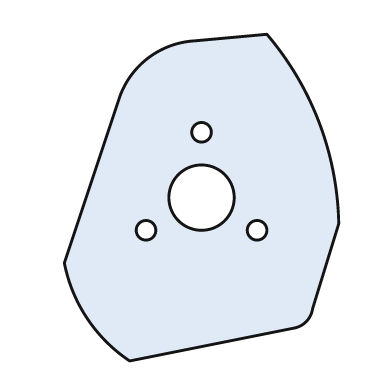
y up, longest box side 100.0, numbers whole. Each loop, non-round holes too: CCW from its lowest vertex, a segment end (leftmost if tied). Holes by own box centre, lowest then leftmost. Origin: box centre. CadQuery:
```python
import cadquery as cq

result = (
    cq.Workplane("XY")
    .moveTo(-22.0, -50.0)
    .lineTo(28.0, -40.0)
    .threePointArc((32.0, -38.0), (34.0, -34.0))
    .lineTo(42.0, -8.0)
    .threePointArc((36.0, 23.0), (20.0, 50.0))
    .lineTo(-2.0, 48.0)
    .threePointArc((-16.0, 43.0), (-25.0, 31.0))
    .lineTo(-42.0, -20.0)
    .threePointArc((-35.0, -37.0), (-22.0, -50.0))
    .close()
    .moveTo(-17.0, -10.0)
    .circle(3.0)
    .moveTo(17.0, -10.0)
    .circle(3.0)
    .moveTo(0.0, 0.0)
    .circle(10.0)
    .moveTo(0.0, 20.0)
    .circle(3.0)
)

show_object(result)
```